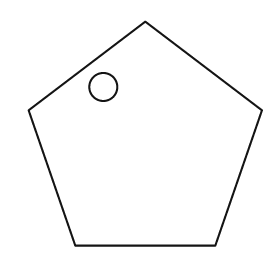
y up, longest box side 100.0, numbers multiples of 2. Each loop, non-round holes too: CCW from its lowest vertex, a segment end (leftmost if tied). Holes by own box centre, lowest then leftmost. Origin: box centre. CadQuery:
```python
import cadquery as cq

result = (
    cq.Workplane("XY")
    .moveTo(-30.0, -48.0)
    .lineTo(30.0, -48.0)
    .lineTo(50.0, 10.0)
    .lineTo(0.0, 48.0)
    .lineTo(-50.0, 10.0)
    .close()
    .moveTo(-18.0, 20.0)
    .circle(6.0)
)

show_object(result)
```